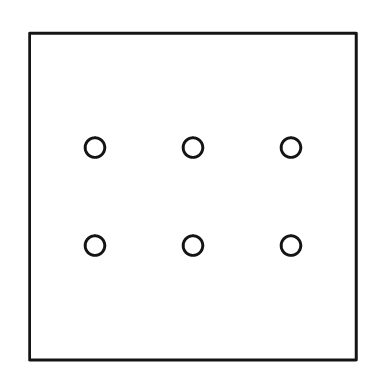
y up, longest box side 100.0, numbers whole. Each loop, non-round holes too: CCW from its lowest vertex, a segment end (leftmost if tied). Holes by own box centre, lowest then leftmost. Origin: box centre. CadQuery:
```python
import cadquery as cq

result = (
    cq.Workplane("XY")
    .moveTo(-50.0, -50.0)
    .lineTo(50.0, -50.0)
    .lineTo(50.0, 50.0)
    .lineTo(-50.0, 50.0)
    .close()
    .moveTo(-30.0, -15.0)
    .circle(3.0)
    .moveTo(0.0, -15.0)
    .circle(3.0)
    .moveTo(30.0, -15.0)
    .circle(3.0)
    .moveTo(-30.0, 15.0)
    .circle(3.0)
    .moveTo(0.0, 15.0)
    .circle(3.0)
    .moveTo(30.0, 15.0)
    .circle(3.0)
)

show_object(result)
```